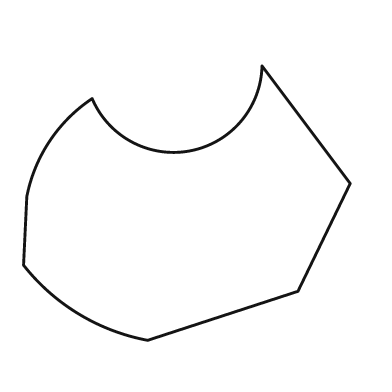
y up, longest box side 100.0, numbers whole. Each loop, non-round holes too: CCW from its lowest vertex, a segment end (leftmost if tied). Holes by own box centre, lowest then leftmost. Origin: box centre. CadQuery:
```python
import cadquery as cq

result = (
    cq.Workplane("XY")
    .moveTo(-12.0, -42.0)
    .lineTo(34.0, -27.0)
    .lineTo(50.0, 6.0)
    .lineTo(23.0, 42.0)
    .threePointArc((1.0, 16.0), (-29.0, 32.0))
    .threePointArc((-42.0, 19.0), (-49.0, 2.0))
    .lineTo(-50.0, -19.0)
    .threePointArc((-33.0, -34.0), (-12.0, -42.0))
    .close()
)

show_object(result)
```